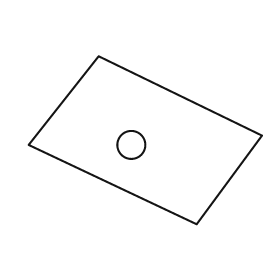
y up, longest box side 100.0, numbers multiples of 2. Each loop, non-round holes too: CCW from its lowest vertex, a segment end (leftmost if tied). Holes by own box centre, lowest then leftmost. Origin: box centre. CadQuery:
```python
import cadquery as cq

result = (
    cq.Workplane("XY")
    .moveTo(22.0, -36.0)
    .lineTo(50.0, 2.0)
    .lineTo(-20.0, 36.0)
    .lineTo(-50.0, -2.0)
    .close()
    .moveTo(-6.0, -2.0)
    .circle(6.0)
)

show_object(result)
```